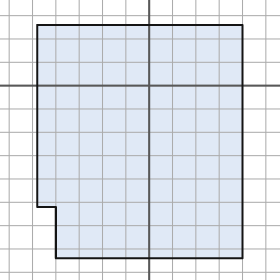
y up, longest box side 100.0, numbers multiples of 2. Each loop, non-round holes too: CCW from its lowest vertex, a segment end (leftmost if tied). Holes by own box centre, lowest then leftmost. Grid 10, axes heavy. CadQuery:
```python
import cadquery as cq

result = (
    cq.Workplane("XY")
    .moveTo(-40.0, -74.0)
    .lineTo(40.0, -74.0)
    .lineTo(40.0, 26.0)
    .lineTo(-48.0, 26.0)
    .lineTo(-48.0, -52.0)
    .lineTo(-40.0, -52.0)
    .close()
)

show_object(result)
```